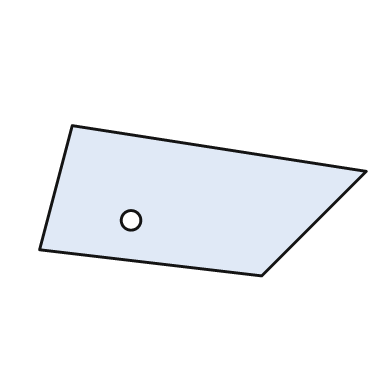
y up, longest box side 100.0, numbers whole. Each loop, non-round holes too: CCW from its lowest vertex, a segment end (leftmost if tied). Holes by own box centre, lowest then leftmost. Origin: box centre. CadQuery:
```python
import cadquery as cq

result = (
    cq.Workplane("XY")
    .moveTo(18.0, -23.0)
    .lineTo(50.0, 9.0)
    .lineTo(-40.0, 23.0)
    .lineTo(-50.0, -15.0)
    .close()
    .moveTo(-22.0, -6.0)
    .circle(3.0)
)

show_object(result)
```